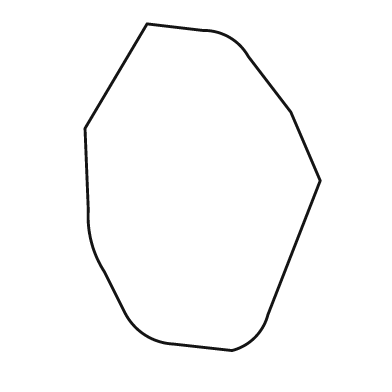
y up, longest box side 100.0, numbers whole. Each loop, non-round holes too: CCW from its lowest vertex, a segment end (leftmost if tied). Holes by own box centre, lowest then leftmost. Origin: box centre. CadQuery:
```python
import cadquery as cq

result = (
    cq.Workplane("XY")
    .moveTo(9.0, -50.0)
    .threePointArc((16.0, -46.0), (20.0, -39.0))
    .lineTo(36.0, 2.0)
    .lineTo(27.0, 23.0)
    .lineTo(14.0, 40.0)
    .threePointArc((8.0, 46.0), (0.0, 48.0))
    .lineTo(-17.0, 50.0)
    .lineTo(-36.0, 18.0)
    .lineTo(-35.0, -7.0)
    .threePointArc((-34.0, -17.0), (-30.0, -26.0))
    .lineTo(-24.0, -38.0)
    .threePointArc((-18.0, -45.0), (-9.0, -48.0))
    .close()
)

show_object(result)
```